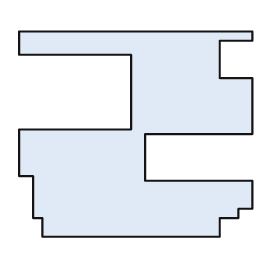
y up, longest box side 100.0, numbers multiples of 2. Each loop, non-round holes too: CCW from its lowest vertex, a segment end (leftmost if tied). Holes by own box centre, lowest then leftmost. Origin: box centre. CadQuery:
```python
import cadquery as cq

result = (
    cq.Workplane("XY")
    .moveTo(-40.0, -44.0)
    .lineTo(36.0, -44.0)
    .lineTo(36.0, -36.0)
    .lineTo(44.0, -36.0)
    .lineTo(44.0, -32.0)
    .lineTo(50.0, -32.0)
    .lineTo(50.0, -20.0)
    .lineTo(4.0, -20.0)
    .lineTo(4.0, 0.0)
    .lineTo(50.0, 0.0)
    .lineTo(50.0, 24.0)
    .lineTo(36.0, 24.0)
    .lineTo(36.0, 40.0)
    .lineTo(50.0, 40.0)
    .lineTo(50.0, 44.0)
    .lineTo(-50.0, 44.0)
    .lineTo(-50.0, 34.0)
    .lineTo(-2.0, 34.0)
    .lineTo(-2.0, 2.0)
    .lineTo(-50.0, 2.0)
    .lineTo(-50.0, -18.0)
    .lineTo(-44.0, -18.0)
    .lineTo(-44.0, -36.0)
    .lineTo(-40.0, -36.0)
    .close()
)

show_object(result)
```